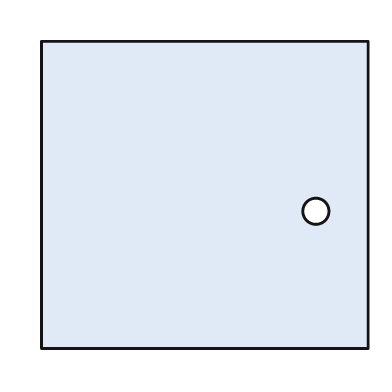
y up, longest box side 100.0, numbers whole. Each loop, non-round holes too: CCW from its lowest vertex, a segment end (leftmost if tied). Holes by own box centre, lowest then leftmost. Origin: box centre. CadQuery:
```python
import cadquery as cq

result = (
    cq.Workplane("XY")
    .moveTo(-50.0, -47.0)
    .lineTo(50.0, -47.0)
    .lineTo(50.0, 47.0)
    .lineTo(-50.0, 47.0)
    .close()
    .moveTo(34.0, -5.0)
    .circle(4.0)
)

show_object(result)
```